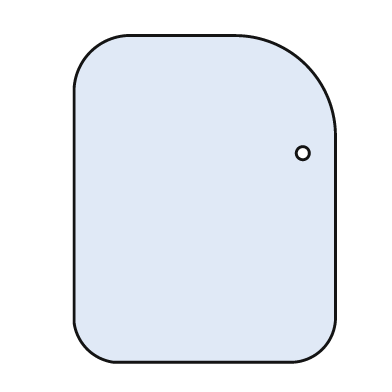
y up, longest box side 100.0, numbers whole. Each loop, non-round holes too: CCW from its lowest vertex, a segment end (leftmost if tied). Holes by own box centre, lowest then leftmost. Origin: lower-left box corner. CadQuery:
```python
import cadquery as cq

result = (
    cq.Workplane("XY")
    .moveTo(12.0, 0.0)
    .lineTo(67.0, 0.0)
    .threePointArc((76.0, 4.0), (80.0, 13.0))
    .lineTo(80.0, 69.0)
    .threePointArc((71.0, 91.0), (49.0, 100.0))
    .lineTo(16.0, 100.0)
    .threePointArc((5.0, 95.0), (0.0, 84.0))
    .lineTo(0.0, 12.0)
    .threePointArc((4.0, 4.0), (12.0, 0.0))
    .close()
    .moveTo(70.0, 64.0)
    .circle(2.0)
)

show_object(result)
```